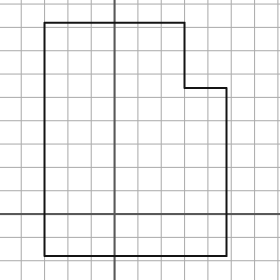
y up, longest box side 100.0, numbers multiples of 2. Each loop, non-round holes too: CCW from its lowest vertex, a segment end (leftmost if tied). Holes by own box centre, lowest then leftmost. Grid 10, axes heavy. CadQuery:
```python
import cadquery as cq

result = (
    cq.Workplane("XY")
    .moveTo(-30.0, -18.0)
    .lineTo(48.0, -18.0)
    .lineTo(48.0, 54.0)
    .lineTo(30.0, 54.0)
    .lineTo(30.0, 82.0)
    .lineTo(-30.0, 82.0)
    .close()
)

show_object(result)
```